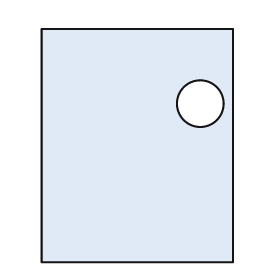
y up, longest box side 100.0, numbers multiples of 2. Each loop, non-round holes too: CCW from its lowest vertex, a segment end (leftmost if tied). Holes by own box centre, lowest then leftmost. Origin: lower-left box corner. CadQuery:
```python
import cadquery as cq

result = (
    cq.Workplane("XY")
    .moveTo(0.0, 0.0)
    .lineTo(82.0, 0.0)
    .lineTo(82.0, 100.0)
    .lineTo(0.0, 100.0)
    .close()
    .moveTo(68.0, 68.0)
    .circle(10.0)
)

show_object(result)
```